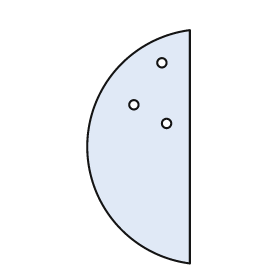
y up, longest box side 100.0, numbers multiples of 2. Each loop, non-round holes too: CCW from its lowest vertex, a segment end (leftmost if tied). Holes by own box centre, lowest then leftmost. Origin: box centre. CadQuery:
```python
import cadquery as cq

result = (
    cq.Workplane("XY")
    .moveTo(22.0, -50.0)
    .lineTo(22.0, 50.0)
    .threePointArc((-22.0, 0.0), (22.0, -50.0))
    .close()
    .moveTo(12.0, 10.0)
    .circle(2.0)
    .moveTo(-2.0, 18.0)
    .circle(2.0)
    .moveTo(10.0, 36.0)
    .circle(2.0)
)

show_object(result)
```